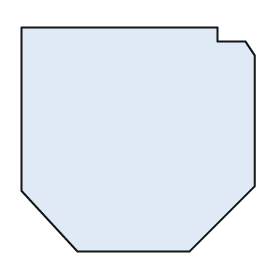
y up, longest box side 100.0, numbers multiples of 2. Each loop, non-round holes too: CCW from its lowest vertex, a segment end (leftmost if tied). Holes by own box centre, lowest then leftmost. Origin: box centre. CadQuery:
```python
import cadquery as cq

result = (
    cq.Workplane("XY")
    .moveTo(-26.0, -48.0)
    .lineTo(22.0, -48.0)
    .lineTo(50.0, -20.0)
    .lineTo(50.0, 36.0)
    .lineTo(46.0, 42.0)
    .lineTo(34.0, 42.0)
    .lineTo(34.0, 48.0)
    .lineTo(-50.0, 48.0)
    .lineTo(-50.0, -22.0)
    .close()
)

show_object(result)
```